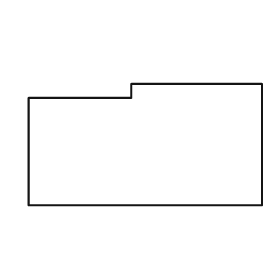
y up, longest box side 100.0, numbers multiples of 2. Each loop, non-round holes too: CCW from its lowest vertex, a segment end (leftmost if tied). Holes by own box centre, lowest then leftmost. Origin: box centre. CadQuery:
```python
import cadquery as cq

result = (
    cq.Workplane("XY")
    .moveTo(-50.0, -26.0)
    .lineTo(50.0, -26.0)
    .lineTo(50.0, 26.0)
    .lineTo(-6.0, 26.0)
    .lineTo(-6.0, 20.0)
    .lineTo(-50.0, 20.0)
    .close()
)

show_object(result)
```